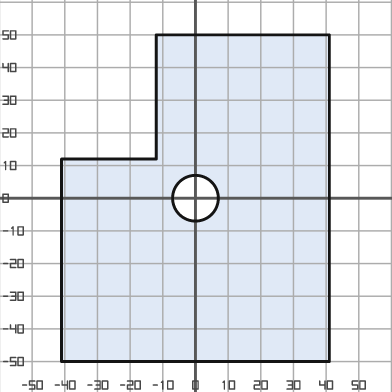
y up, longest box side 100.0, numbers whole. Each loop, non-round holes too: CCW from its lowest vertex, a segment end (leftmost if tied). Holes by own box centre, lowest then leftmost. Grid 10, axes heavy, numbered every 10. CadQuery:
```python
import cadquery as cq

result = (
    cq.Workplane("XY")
    .moveTo(-41.0, -50.0)
    .lineTo(41.0, -50.0)
    .lineTo(41.0, 50.0)
    .lineTo(-12.0, 50.0)
    .lineTo(-12.0, 12.0)
    .lineTo(-41.0, 12.0)
    .close()
    .moveTo(0.0, 0.0)
    .circle(7.0)
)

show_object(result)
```